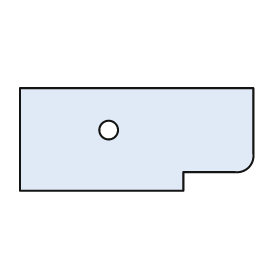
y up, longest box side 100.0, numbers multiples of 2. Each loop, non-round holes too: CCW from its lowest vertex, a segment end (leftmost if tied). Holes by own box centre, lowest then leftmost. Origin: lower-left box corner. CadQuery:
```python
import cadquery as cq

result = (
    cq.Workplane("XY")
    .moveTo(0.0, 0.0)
    .lineTo(70.0, 0.0)
    .lineTo(70.0, 8.0)
    .lineTo(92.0, 8.0)
    .threePointArc((98.0, 10.0), (100.0, 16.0))
    .lineTo(100.0, 44.0)
    .lineTo(0.0, 44.0)
    .close()
    .moveTo(38.0, 26.0)
    .circle(4.0)
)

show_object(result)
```